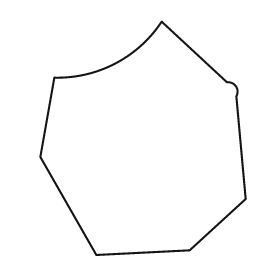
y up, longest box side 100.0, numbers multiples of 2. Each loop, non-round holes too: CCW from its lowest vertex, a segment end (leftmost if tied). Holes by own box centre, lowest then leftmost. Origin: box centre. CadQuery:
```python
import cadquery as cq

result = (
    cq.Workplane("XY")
    .moveTo(-20.0, -50.0)
    .lineTo(20.0, -48.0)
    .lineTo(44.0, -26.0)
    .lineTo(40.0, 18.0)
    .threePointArc((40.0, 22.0), (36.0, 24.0))
    .lineTo(8.0, 50.0)
    .threePointArc((-12.0, 32.0), (-38.0, 26.0))
    .lineTo(-44.0, -8.0)
    .close()
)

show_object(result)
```